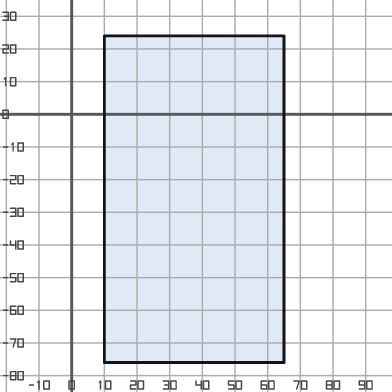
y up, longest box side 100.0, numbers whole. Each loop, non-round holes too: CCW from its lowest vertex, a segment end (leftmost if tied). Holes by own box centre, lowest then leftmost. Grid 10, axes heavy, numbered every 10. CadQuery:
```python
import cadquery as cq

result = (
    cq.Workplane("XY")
    .moveTo(10.0, -76.0)
    .lineTo(65.0, -76.0)
    .lineTo(65.0, 24.0)
    .lineTo(10.0, 24.0)
    .close()
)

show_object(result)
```